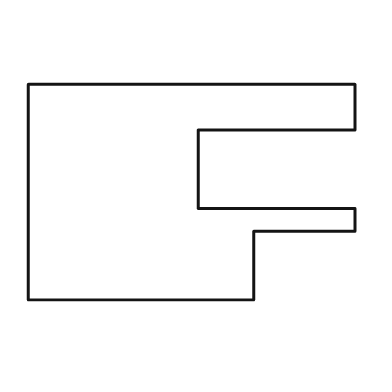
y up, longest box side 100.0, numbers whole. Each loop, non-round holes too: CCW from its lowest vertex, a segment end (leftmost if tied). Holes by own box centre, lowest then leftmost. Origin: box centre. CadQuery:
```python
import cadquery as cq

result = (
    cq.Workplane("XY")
    .moveTo(-50.0, -33.0)
    .lineTo(19.0, -33.0)
    .lineTo(19.0, -12.0)
    .lineTo(50.0, -12.0)
    .lineTo(50.0, -5.0)
    .lineTo(2.0, -5.0)
    .lineTo(2.0, 19.0)
    .lineTo(50.0, 19.0)
    .lineTo(50.0, 33.0)
    .lineTo(-50.0, 33.0)
    .close()
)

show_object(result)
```